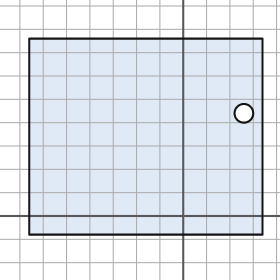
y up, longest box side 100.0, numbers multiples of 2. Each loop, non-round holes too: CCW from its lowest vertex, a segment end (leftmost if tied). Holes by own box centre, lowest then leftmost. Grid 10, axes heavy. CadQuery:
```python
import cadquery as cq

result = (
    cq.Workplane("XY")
    .moveTo(-66.0, -8.0)
    .lineTo(34.0, -8.0)
    .lineTo(34.0, 76.0)
    .lineTo(-66.0, 76.0)
    .close()
    .moveTo(26.0, 44.0)
    .circle(4.0)
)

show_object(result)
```